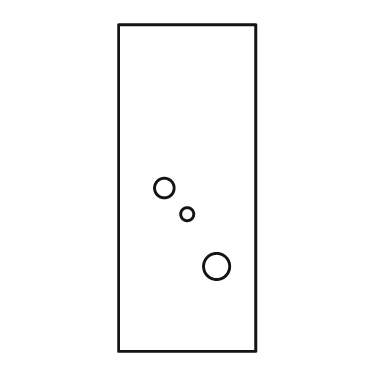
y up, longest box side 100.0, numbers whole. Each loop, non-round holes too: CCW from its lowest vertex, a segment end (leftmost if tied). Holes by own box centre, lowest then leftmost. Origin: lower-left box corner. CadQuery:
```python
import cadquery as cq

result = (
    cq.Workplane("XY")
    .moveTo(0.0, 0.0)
    .lineTo(42.0, 0.0)
    .lineTo(42.0, 100.0)
    .lineTo(0.0, 100.0)
    .close()
    .moveTo(30.0, 26.0)
    .circle(4.0)
    .moveTo(21.0, 42.0)
    .circle(2.0)
    .moveTo(14.0, 50.0)
    .circle(3.0)
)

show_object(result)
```